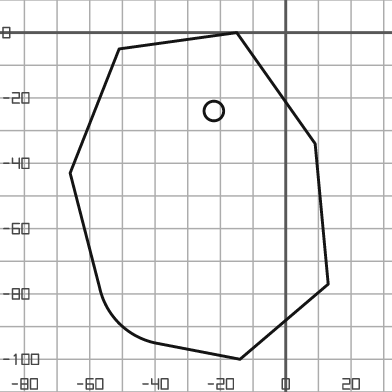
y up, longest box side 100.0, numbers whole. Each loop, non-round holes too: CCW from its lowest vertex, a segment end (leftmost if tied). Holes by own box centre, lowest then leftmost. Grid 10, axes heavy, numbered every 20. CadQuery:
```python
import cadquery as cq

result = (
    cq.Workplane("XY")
    .moveTo(-14.0, -100.0)
    .lineTo(13.0, -77.0)
    .lineTo(9.0, -34.0)
    .lineTo(-15.0, 0.0)
    .lineTo(-51.0, -5.0)
    .lineTo(-66.0, -43.0)
    .lineTo(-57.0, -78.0)
    .threePointArc((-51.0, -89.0), (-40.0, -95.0))
    .close()
    .moveTo(-22.0, -24.0)
    .circle(3.0)
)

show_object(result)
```